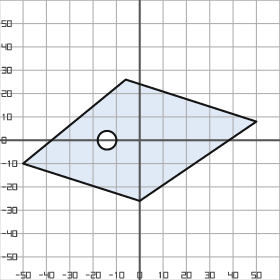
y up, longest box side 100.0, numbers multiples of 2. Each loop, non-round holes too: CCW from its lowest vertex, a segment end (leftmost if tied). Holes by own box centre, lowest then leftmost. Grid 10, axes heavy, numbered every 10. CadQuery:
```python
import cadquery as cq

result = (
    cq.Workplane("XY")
    .moveTo(0.0, -26.0)
    .lineTo(50.0, 8.0)
    .lineTo(-6.0, 26.0)
    .lineTo(-50.0, -10.0)
    .close()
    .moveTo(-14.0, 0.0)
    .circle(4.0)
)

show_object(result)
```